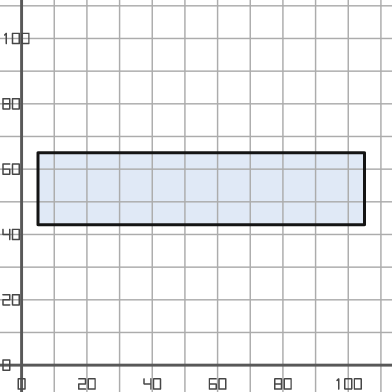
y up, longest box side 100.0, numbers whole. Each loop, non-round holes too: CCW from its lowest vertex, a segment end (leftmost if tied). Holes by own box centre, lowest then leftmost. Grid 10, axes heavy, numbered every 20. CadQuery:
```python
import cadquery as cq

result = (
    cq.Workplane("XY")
    .moveTo(5.0, 43.0)
    .lineTo(105.0, 43.0)
    .lineTo(105.0, 65.0)
    .lineTo(5.0, 65.0)
    .close()
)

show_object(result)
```